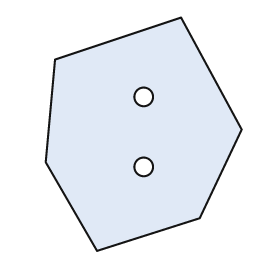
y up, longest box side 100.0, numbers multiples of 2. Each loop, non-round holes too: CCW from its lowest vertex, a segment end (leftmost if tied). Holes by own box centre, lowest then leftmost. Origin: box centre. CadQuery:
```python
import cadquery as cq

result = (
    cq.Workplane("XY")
    .moveTo(-20.0, -50.0)
    .lineTo(24.0, -36.0)
    .lineTo(42.0, 2.0)
    .lineTo(16.0, 50.0)
    .lineTo(-38.0, 32.0)
    .lineTo(-42.0, -12.0)
    .close()
    .moveTo(0.0, -14.0)
    .circle(4.0)
    .moveTo(0.0, 16.0)
    .circle(4.0)
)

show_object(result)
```